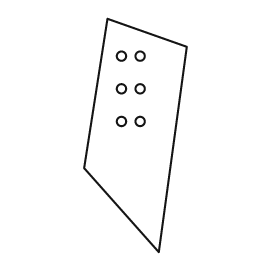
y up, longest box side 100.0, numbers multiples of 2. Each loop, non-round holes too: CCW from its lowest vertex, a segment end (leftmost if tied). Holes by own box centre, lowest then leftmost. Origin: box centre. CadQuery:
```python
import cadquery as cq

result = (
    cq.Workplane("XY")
    .moveTo(10.0, -50.0)
    .lineTo(22.0, 38.0)
    .lineTo(-12.0, 50.0)
    .lineTo(-22.0, -14.0)
    .close()
    .moveTo(-6.0, 6.0)
    .circle(2.0)
    .moveTo(2.0, 6.0)
    .circle(2.0)
    .moveTo(-6.0, 20.0)
    .circle(2.0)
    .moveTo(2.0, 20.0)
    .circle(2.0)
    .moveTo(-6.0, 34.0)
    .circle(2.0)
    .moveTo(2.0, 34.0)
    .circle(2.0)
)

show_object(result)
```